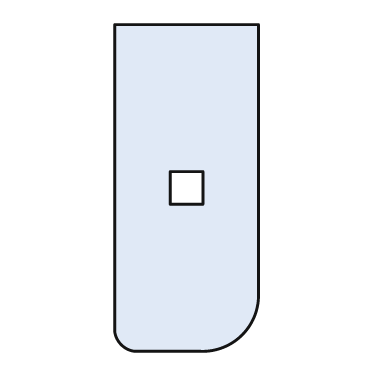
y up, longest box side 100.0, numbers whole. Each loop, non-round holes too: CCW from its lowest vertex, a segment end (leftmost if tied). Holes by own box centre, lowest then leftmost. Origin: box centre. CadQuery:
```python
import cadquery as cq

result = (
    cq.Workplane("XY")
    .moveTo(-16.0, -50.0)
    .lineTo(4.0, -50.0)
    .threePointArc((17.0, -45.0), (22.0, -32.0))
    .lineTo(22.0, 50.0)
    .lineTo(-22.0, 50.0)
    .lineTo(-22.0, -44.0)
    .threePointArc((-20.0, -48.0), (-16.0, -50.0))
    .close()
    .moveTo(-5.0, -5.0)
    .lineTo(5.0, -5.0)
    .lineTo(5.0, 5.0)
    .lineTo(-5.0, 5.0)
    .close()
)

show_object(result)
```